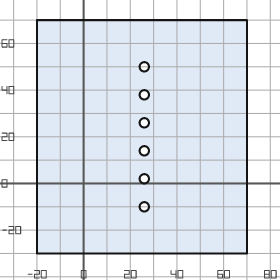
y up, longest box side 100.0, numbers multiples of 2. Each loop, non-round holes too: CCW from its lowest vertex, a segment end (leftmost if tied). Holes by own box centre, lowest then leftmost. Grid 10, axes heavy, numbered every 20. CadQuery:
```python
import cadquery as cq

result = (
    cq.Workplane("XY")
    .moveTo(-20.0, -30.0)
    .lineTo(70.0, -30.0)
    .lineTo(70.0, 70.0)
    .lineTo(-20.0, 70.0)
    .close()
    .moveTo(26.0, -10.0)
    .circle(2.0)
    .moveTo(26.0, 2.0)
    .circle(2.0)
    .moveTo(26.0, 14.0)
    .circle(2.0)
    .moveTo(26.0, 26.0)
    .circle(2.0)
    .moveTo(26.0, 38.0)
    .circle(2.0)
    .moveTo(26.0, 50.0)
    .circle(2.0)
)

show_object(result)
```